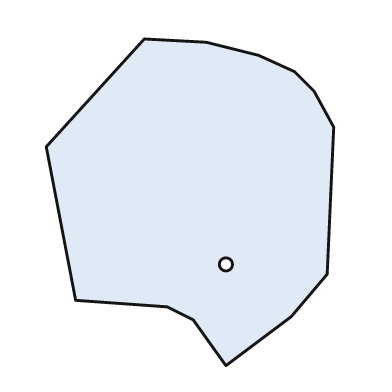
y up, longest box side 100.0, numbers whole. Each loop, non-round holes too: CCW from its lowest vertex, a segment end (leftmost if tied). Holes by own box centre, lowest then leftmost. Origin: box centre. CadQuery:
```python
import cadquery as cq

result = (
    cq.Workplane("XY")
    .moveTo(11.0, -50.0)
    .lineTo(31.0, -35.0)
    .lineTo(42.0, -22.0)
    .lineTo(44.0, 23.0)
    .lineTo(38.0, 34.0)
    .lineTo(32.0, 40.0)
    .lineTo(21.0, 45.0)
    .lineTo(5.0, 49.0)
    .lineTo(-14.0, 50.0)
    .lineTo(-44.0, 17.0)
    .lineTo(-35.0, -30.0)
    .lineTo(-7.0, -32.0)
    .lineTo(1.0, -36.0)
    .close()
    .moveTo(11.0, -19.0)
    .circle(2.0)
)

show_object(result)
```